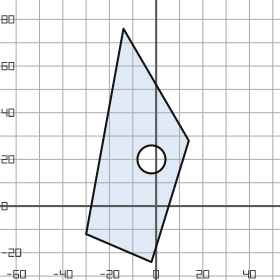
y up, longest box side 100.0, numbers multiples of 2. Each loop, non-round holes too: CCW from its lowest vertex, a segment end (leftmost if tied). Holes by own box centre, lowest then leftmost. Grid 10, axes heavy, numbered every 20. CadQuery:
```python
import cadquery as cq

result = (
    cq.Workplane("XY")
    .moveTo(-2.0, -24.0)
    .lineTo(14.0, 28.0)
    .lineTo(-14.0, 76.0)
    .lineTo(-30.0, -12.0)
    .close()
    .moveTo(-2.0, 20.0)
    .circle(6.0)
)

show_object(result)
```